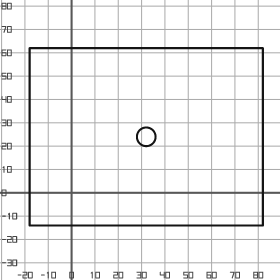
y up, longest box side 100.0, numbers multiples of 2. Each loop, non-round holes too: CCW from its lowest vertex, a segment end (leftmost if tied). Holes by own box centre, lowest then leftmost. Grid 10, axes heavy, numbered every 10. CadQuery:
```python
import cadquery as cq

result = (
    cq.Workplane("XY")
    .moveTo(-18.0, -14.0)
    .lineTo(82.0, -14.0)
    .lineTo(82.0, 62.0)
    .lineTo(-18.0, 62.0)
    .close()
    .moveTo(32.0, 24.0)
    .circle(4.0)
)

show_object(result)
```